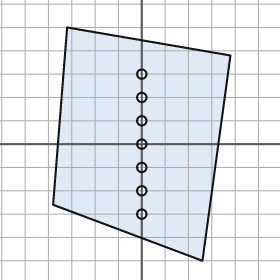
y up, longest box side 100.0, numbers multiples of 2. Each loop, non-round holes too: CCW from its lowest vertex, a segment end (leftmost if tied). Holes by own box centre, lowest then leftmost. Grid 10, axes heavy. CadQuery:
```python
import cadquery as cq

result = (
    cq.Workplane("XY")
    .moveTo(26.0, -50.0)
    .lineTo(38.0, 38.0)
    .lineTo(-32.0, 50.0)
    .lineTo(-38.0, -26.0)
    .close()
    .moveTo(0.0, -30.0)
    .circle(2.0)
    .moveTo(0.0, -20.0)
    .circle(2.0)
    .moveTo(0.0, -10.0)
    .circle(2.0)
    .moveTo(0.0, 0.0)
    .circle(2.0)
    .moveTo(0.0, 10.0)
    .circle(2.0)
    .moveTo(0.0, 20.0)
    .circle(2.0)
    .moveTo(0.0, 30.0)
    .circle(2.0)
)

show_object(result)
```